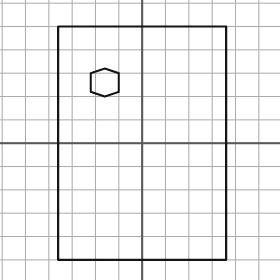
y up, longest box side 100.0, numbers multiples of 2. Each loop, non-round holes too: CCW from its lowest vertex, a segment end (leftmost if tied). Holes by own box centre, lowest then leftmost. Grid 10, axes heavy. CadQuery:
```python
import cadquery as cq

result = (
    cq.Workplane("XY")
    .moveTo(-36.0, -50.0)
    .lineTo(36.0, -50.0)
    .lineTo(36.0, 50.0)
    .lineTo(-36.0, 50.0)
    .close()
    .moveTo(-16.0, 20.0)
    .lineTo(-10.0, 22.0)
    .lineTo(-10.0, 30.0)
    .lineTo(-16.0, 32.0)
    .lineTo(-22.0, 30.0)
    .lineTo(-22.0, 22.0)
    .close()
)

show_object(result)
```